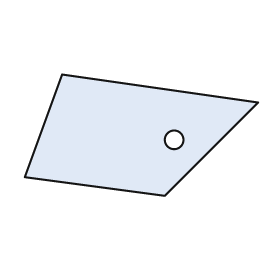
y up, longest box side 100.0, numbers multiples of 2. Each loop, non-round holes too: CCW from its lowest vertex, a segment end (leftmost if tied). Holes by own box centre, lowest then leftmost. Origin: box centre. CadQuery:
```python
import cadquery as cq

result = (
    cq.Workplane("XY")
    .moveTo(10.0, -26.0)
    .lineTo(50.0, 14.0)
    .lineTo(-34.0, 26.0)
    .lineTo(-50.0, -18.0)
    .close()
    .moveTo(14.0, -2.0)
    .circle(4.0)
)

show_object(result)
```